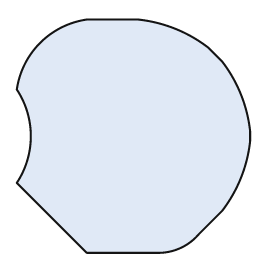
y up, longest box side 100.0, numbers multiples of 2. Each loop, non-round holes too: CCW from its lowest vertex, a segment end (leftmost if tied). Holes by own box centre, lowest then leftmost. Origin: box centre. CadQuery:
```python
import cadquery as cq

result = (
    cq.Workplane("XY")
    .moveTo(-20.0, -50.0)
    .lineTo(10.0, -50.0)
    .threePointArc((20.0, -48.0), (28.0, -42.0))
    .lineTo(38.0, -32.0)
    .threePointArc((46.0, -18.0), (50.0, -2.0))
    .lineTo(50.0, 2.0)
    .threePointArc((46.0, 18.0), (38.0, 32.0))
    .lineTo(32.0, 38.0)
    .threePointArc((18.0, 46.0), (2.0, 50.0))
    .lineTo(-20.0, 50.0)
    .threePointArc((-40.0, 40.0), (-50.0, 20.0))
    .threePointArc((-44.0, 0.0), (-50.0, -20.0))
    .close()
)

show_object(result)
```